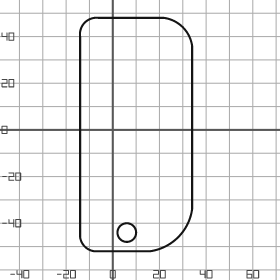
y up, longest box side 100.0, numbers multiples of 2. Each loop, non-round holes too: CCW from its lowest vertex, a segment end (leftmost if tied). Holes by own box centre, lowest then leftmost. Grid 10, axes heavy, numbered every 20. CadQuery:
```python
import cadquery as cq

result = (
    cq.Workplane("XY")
    .moveTo(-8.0, -52.0)
    .lineTo(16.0, -52.0)
    .threePointArc((28.0, -46.0), (34.0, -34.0))
    .lineTo(34.0, 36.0)
    .threePointArc((30.0, 44.0), (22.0, 48.0))
    .lineTo(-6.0, 48.0)
    .threePointArc((-12.0, 46.0), (-14.0, 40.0))
    .lineTo(-14.0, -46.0)
    .threePointArc((-12.0, -50.0), (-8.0, -52.0))
    .close()
    .moveTo(6.0, -44.0)
    .circle(4.0)
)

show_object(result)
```